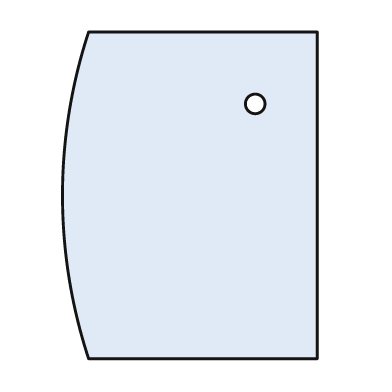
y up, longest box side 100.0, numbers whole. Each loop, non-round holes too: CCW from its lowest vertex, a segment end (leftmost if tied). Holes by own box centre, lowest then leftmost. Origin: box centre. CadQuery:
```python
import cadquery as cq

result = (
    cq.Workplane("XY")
    .moveTo(-31.0, -50.0)
    .lineTo(39.0, -50.0)
    .lineTo(39.0, 50.0)
    .lineTo(-31.0, 50.0)
    .threePointArc((-39.0, 0.0), (-31.0, -50.0))
    .close()
    .moveTo(20.0, 28.0)
    .circle(3.0)
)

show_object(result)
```